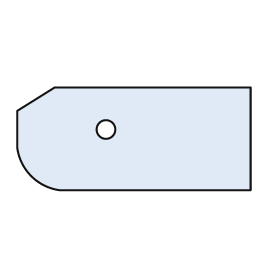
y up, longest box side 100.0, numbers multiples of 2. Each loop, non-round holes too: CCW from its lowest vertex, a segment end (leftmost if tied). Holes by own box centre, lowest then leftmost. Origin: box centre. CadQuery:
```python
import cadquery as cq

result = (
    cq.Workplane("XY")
    .moveTo(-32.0, -22.0)
    .lineTo(50.0, -22.0)
    .lineTo(50.0, 22.0)
    .lineTo(-34.0, 22.0)
    .lineTo(-50.0, 12.0)
    .lineTo(-50.0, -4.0)
    .threePointArc((-44.0, -16.0), (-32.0, -22.0))
    .close()
    .moveTo(-12.0, 4.0)
    .circle(4.0)
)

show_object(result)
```